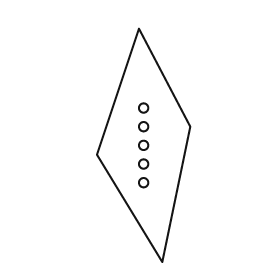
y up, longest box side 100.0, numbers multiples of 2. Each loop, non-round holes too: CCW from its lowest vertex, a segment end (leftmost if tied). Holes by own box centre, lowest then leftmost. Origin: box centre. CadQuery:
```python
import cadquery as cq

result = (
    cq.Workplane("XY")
    .moveTo(8.0, -50.0)
    .lineTo(20.0, 8.0)
    .lineTo(-2.0, 50.0)
    .lineTo(-20.0, -4.0)
    .close()
    .moveTo(0.0, -16.0)
    .circle(2.0)
    .moveTo(0.0, -8.0)
    .circle(2.0)
    .moveTo(0.0, 0.0)
    .circle(2.0)
    .moveTo(0.0, 8.0)
    .circle(2.0)
    .moveTo(0.0, 16.0)
    .circle(2.0)
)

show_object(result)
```